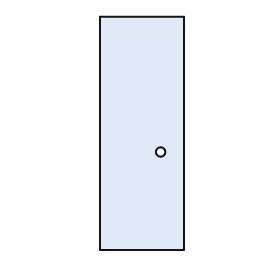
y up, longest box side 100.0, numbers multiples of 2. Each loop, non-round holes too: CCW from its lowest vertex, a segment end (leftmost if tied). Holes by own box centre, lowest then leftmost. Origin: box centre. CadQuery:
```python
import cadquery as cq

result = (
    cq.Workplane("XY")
    .moveTo(-18.0, -50.0)
    .lineTo(18.0, -50.0)
    .lineTo(18.0, 50.0)
    .lineTo(-18.0, 50.0)
    .close()
    .moveTo(8.0, -8.0)
    .circle(2.0)
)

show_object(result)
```